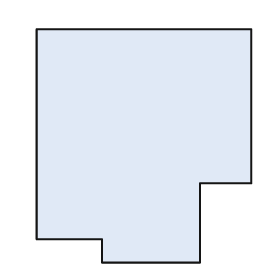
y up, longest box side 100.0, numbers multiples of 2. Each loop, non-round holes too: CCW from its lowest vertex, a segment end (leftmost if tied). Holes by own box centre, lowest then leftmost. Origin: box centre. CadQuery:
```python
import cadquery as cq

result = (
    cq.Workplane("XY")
    .moveTo(-18.0, -50.0)
    .lineTo(24.0, -50.0)
    .lineTo(24.0, -16.0)
    .lineTo(46.0, -16.0)
    .lineTo(46.0, 50.0)
    .lineTo(-46.0, 50.0)
    .lineTo(-46.0, -40.0)
    .lineTo(-18.0, -40.0)
    .close()
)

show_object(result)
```